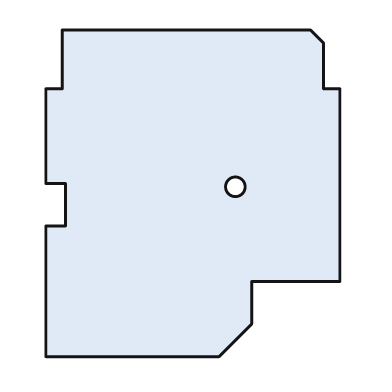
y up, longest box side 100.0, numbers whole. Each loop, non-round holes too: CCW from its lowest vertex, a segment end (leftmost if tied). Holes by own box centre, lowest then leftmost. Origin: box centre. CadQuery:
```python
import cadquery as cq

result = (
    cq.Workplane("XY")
    .moveTo(-45.0, -50.0)
    .lineTo(8.0, -50.0)
    .lineTo(18.0, -40.0)
    .lineTo(18.0, -27.0)
    .lineTo(45.0, -27.0)
    .lineTo(45.0, 32.0)
    .lineTo(40.0, 32.0)
    .lineTo(40.0, 46.0)
    .lineTo(36.0, 50.0)
    .lineTo(-40.0, 50.0)
    .lineTo(-40.0, 32.0)
    .lineTo(-45.0, 32.0)
    .lineTo(-45.0, 3.0)
    .lineTo(-39.0, 3.0)
    .lineTo(-39.0, -10.0)
    .lineTo(-45.0, -10.0)
    .close()
    .moveTo(13.0, 2.0)
    .circle(3.0)
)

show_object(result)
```